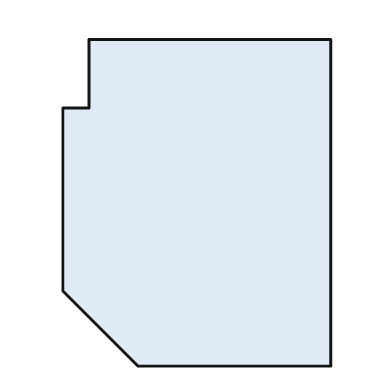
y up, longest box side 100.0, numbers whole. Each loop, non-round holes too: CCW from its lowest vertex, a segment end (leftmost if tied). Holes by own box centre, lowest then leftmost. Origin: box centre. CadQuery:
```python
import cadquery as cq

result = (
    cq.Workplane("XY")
    .moveTo(-18.0, -50.0)
    .lineTo(41.0, -50.0)
    .lineTo(41.0, 50.0)
    .lineTo(-33.0, 50.0)
    .lineTo(-33.0, 29.0)
    .lineTo(-41.0, 29.0)
    .lineTo(-41.0, -27.0)
    .close()
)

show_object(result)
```